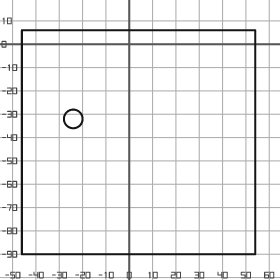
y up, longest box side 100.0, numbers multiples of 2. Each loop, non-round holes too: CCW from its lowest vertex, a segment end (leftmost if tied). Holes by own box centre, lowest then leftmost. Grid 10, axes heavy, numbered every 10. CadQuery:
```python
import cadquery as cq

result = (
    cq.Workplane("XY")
    .moveTo(-46.0, -90.0)
    .lineTo(54.0, -90.0)
    .lineTo(54.0, 6.0)
    .lineTo(-46.0, 6.0)
    .close()
    .moveTo(-24.0, -32.0)
    .circle(4.0)
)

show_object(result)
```